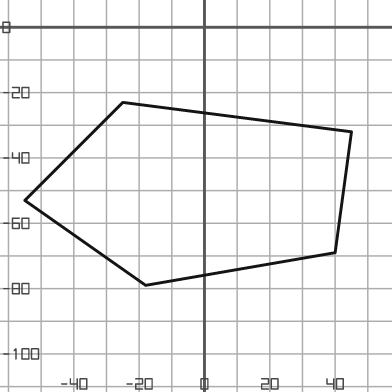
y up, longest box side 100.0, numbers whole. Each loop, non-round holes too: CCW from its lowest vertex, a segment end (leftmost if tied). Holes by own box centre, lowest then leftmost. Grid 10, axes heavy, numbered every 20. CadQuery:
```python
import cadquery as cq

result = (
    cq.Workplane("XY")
    .moveTo(-18.0, -79.0)
    .lineTo(40.0, -69.0)
    .lineTo(45.0, -32.0)
    .lineTo(-25.0, -23.0)
    .lineTo(-55.0, -53.0)
    .close()
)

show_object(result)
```